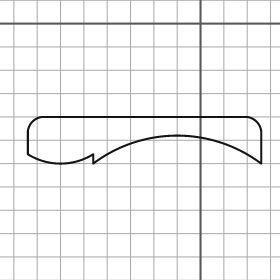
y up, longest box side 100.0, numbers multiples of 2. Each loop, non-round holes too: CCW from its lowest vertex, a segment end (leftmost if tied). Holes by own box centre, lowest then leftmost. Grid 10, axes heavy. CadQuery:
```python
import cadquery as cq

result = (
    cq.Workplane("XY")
    .moveTo(-46.0, -60.0)
    .threePointArc((-10.0, -48.0), (26.0, -60.0))
    .lineTo(26.0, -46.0)
    .threePointArc((24.0, -42.0), (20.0, -40.0))
    .lineTo(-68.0, -40.0)
    .threePointArc((-72.0, -42.0), (-74.0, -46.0))
    .lineTo(-74.0, -56.0)
    .threePointArc((-60.0, -60.0), (-46.0, -56.0))
    .close()
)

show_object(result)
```